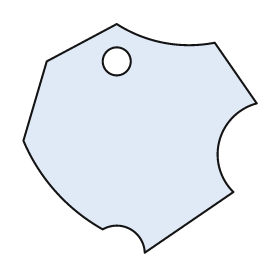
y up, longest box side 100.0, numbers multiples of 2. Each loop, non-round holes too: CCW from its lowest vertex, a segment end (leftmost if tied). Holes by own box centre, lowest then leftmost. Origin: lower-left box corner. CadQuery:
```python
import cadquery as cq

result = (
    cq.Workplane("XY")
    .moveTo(52.0, 0.0)
    .lineTo(90.0, 26.0)
    .threePointArc((84.0, 48.0), (100.0, 64.0))
    .lineTo(82.0, 90.0)
    .threePointArc((60.0, 90.0), (40.0, 98.0))
    .lineTo(10.0, 82.0)
    .lineTo(0.0, 48.0)
    .threePointArc((14.0, 26.0), (34.0, 10.0))
    .threePointArc((46.0, 10.0), (52.0, 0.0))
    .close()
    .moveTo(40.0, 82.0)
    .circle(6.0)
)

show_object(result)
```